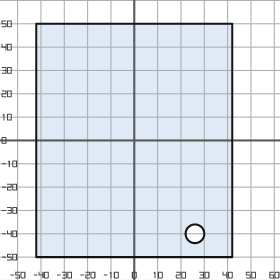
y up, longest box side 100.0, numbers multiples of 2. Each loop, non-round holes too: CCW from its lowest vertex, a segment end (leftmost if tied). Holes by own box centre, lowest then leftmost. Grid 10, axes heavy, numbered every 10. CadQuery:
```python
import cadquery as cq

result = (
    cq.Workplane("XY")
    .moveTo(-42.0, -50.0)
    .lineTo(42.0, -50.0)
    .lineTo(42.0, 50.0)
    .lineTo(-42.0, 50.0)
    .close()
    .moveTo(26.0, -40.0)
    .circle(4.0)
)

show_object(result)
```